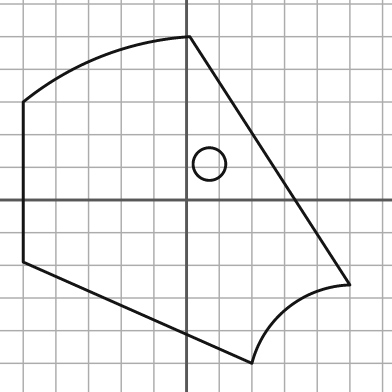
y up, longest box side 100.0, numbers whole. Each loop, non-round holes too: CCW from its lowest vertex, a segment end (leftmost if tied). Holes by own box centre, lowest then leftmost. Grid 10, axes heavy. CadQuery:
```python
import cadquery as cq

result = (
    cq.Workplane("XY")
    .moveTo(20.0, -50.0)
    .threePointArc((31.0, -33.0), (50.0, -26.0))
    .lineTo(1.0, 50.0)
    .threePointArc((-26.0, 44.0), (-50.0, 30.0))
    .lineTo(-50.0, -19.0)
    .close()
    .moveTo(7.0, 11.0)
    .circle(5.0)
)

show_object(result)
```